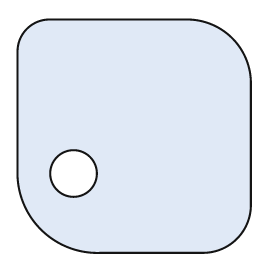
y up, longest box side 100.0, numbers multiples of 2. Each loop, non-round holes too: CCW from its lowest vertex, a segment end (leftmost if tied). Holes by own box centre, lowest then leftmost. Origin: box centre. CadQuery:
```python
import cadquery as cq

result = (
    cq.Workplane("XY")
    .moveTo(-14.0, -50.0)
    .lineTo(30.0, -50.0)
    .threePointArc((44.0, -44.0), (50.0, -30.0))
    .lineTo(50.0, 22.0)
    .threePointArc((42.0, 42.0), (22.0, 50.0))
    .lineTo(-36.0, 50.0)
    .threePointArc((-46.0, 46.0), (-50.0, 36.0))
    .lineTo(-50.0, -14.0)
    .threePointArc((-40.0, -40.0), (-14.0, -50.0))
    .close()
    .moveTo(-26.0, -16.0)
    .circle(10.0)
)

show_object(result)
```